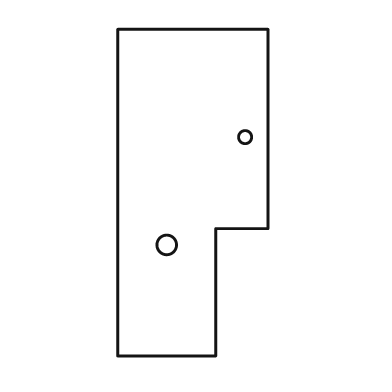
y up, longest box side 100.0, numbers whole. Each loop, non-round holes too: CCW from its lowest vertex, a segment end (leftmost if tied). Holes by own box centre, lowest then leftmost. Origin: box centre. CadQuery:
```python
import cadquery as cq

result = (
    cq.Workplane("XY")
    .moveTo(-23.0, -50.0)
    .lineTo(7.0, -50.0)
    .lineTo(7.0, -11.0)
    .lineTo(23.0, -11.0)
    .lineTo(23.0, 50.0)
    .lineTo(-23.0, 50.0)
    .close()
    .moveTo(-8.0, -16.0)
    .circle(3.0)
    .moveTo(16.0, 17.0)
    .circle(2.0)
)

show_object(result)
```